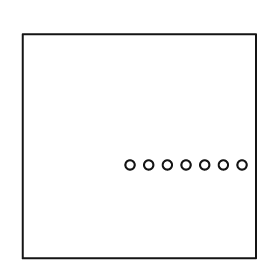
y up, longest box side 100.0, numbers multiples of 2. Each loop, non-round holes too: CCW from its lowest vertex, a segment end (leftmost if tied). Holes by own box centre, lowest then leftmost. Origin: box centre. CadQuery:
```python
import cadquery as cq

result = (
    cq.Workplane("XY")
    .moveTo(-50.0, -48.0)
    .lineTo(50.0, -48.0)
    .lineTo(50.0, 48.0)
    .lineTo(-50.0, 48.0)
    .close()
    .moveTo(-4.0, -8.0)
    .circle(2.0)
    .moveTo(4.0, -8.0)
    .circle(2.0)
    .moveTo(12.0, -8.0)
    .circle(2.0)
    .moveTo(20.0, -8.0)
    .circle(2.0)
    .moveTo(28.0, -8.0)
    .circle(2.0)
    .moveTo(36.0, -8.0)
    .circle(2.0)
    .moveTo(44.0, -8.0)
    .circle(2.0)
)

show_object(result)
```